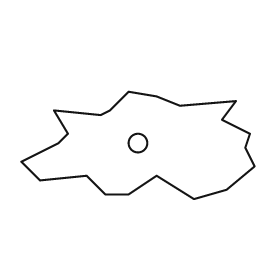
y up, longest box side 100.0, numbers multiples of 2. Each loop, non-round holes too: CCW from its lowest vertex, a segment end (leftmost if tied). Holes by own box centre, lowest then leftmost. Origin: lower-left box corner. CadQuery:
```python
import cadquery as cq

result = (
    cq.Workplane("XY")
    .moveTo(74.0, 0.0)
    .lineTo(88.0, 4.0)
    .lineTo(100.0, 14.0)
    .lineTo(96.0, 22.0)
    .lineTo(98.0, 28.0)
    .lineTo(86.0, 34.0)
    .lineTo(92.0, 42.0)
    .lineTo(68.0, 40.0)
    .lineTo(58.0, 44.0)
    .lineTo(46.0, 46.0)
    .lineTo(38.0, 38.0)
    .lineTo(34.0, 36.0)
    .lineTo(14.0, 38.0)
    .lineTo(20.0, 28.0)
    .lineTo(16.0, 24.0)
    .lineTo(0.0, 16.0)
    .lineTo(8.0, 8.0)
    .lineTo(28.0, 10.0)
    .lineTo(36.0, 2.0)
    .lineTo(46.0, 2.0)
    .lineTo(58.0, 10.0)
    .close()
    .moveTo(50.0, 24.0)
    .circle(4.0)
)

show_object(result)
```